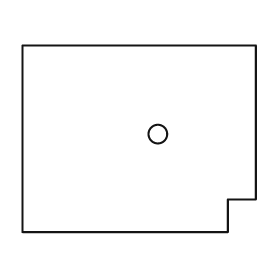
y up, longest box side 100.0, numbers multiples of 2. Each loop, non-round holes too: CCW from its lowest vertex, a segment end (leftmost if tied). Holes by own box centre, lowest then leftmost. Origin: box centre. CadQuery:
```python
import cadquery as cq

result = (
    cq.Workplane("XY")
    .moveTo(-50.0, -40.0)
    .lineTo(38.0, -40.0)
    .lineTo(38.0, -26.0)
    .lineTo(50.0, -26.0)
    .lineTo(50.0, 40.0)
    .lineTo(-50.0, 40.0)
    .close()
    .moveTo(8.0, 2.0)
    .circle(4.0)
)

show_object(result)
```